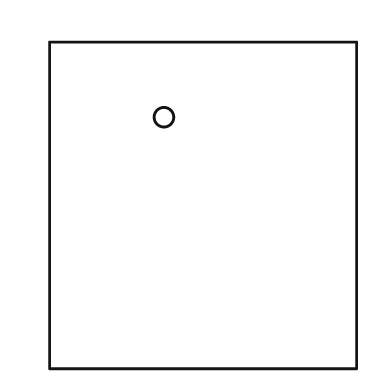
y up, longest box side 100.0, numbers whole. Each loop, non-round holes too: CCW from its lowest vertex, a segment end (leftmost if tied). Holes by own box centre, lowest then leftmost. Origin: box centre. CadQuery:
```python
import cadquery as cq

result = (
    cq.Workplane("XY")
    .moveTo(-47.0, -50.0)
    .lineTo(47.0, -50.0)
    .lineTo(47.0, 50.0)
    .lineTo(-47.0, 50.0)
    .close()
    .moveTo(-12.0, 27.0)
    .circle(3.0)
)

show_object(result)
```